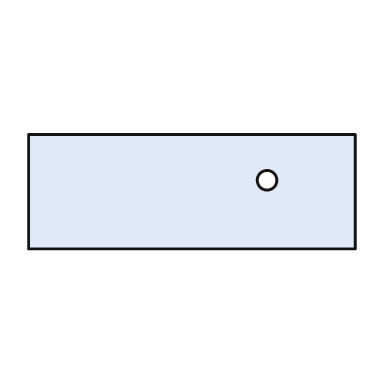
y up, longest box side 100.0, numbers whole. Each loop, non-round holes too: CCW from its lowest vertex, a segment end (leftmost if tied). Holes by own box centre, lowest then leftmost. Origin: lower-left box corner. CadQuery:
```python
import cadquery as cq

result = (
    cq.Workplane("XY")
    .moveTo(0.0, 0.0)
    .lineTo(100.0, 0.0)
    .lineTo(100.0, 35.0)
    .lineTo(0.0, 35.0)
    .close()
    .moveTo(73.0, 21.0)
    .circle(3.0)
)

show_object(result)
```